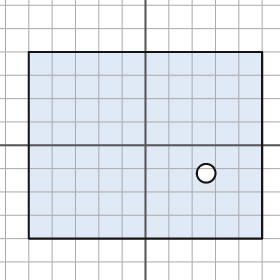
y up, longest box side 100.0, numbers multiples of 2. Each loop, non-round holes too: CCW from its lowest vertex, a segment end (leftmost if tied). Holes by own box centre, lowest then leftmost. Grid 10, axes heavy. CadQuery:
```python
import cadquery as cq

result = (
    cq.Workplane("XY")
    .moveTo(-50.0, -40.0)
    .lineTo(50.0, -40.0)
    .lineTo(50.0, 40.0)
    .lineTo(-50.0, 40.0)
    .close()
    .moveTo(26.0, -12.0)
    .circle(4.0)
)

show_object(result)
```